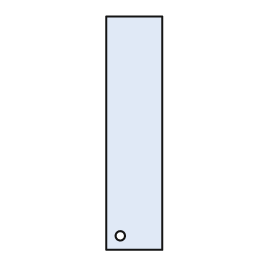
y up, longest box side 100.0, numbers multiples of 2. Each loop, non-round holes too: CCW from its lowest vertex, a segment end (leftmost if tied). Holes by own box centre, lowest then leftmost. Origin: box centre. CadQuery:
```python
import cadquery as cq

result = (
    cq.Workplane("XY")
    .moveTo(-12.0, -50.0)
    .lineTo(12.0, -50.0)
    .lineTo(12.0, 50.0)
    .lineTo(-12.0, 50.0)
    .close()
    .moveTo(-6.0, -44.0)
    .circle(2.0)
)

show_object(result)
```